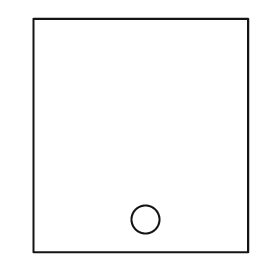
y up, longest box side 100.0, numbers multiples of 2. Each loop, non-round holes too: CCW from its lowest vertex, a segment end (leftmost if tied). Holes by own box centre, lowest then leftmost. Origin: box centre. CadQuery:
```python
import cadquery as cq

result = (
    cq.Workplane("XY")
    .moveTo(-46.0, -50.0)
    .lineTo(46.0, -50.0)
    .lineTo(46.0, 50.0)
    .lineTo(-46.0, 50.0)
    .close()
    .moveTo(2.0, -36.0)
    .circle(6.0)
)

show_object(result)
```